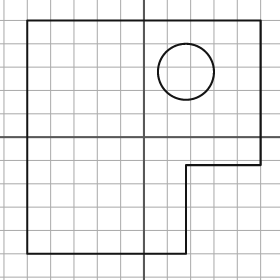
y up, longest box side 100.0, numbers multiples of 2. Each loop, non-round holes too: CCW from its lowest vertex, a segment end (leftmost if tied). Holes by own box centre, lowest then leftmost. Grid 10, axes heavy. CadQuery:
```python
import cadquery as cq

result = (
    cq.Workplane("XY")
    .moveTo(-50.0, -50.0)
    .lineTo(18.0, -50.0)
    .lineTo(18.0, -12.0)
    .lineTo(50.0, -12.0)
    .lineTo(50.0, 50.0)
    .lineTo(-50.0, 50.0)
    .close()
    .moveTo(18.0, 28.0)
    .circle(12.0)
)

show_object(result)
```